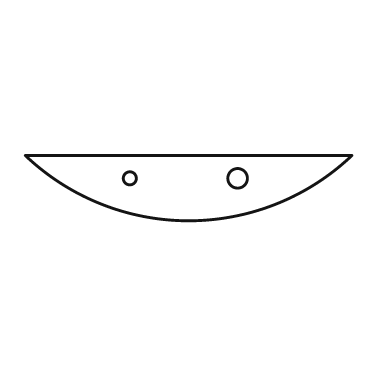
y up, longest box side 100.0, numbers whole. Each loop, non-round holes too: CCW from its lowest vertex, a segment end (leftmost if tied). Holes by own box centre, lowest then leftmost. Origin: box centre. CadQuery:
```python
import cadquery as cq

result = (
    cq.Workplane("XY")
    .moveTo(-50.0, 10.0)
    .threePointArc((0.0, -10.0), (50.0, 10.0))
    .close()
    .moveTo(-18.0, 3.0)
    .circle(2.0)
    .moveTo(15.0, 3.0)
    .circle(3.0)
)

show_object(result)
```